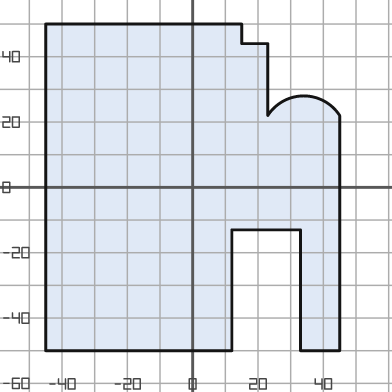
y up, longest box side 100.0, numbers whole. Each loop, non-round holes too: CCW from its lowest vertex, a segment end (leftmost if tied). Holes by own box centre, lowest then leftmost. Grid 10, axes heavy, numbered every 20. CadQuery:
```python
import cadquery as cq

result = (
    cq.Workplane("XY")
    .moveTo(-45.0, -50.0)
    .lineTo(12.0, -50.0)
    .lineTo(12.0, -13.0)
    .lineTo(33.0, -13.0)
    .lineTo(33.0, -50.0)
    .lineTo(45.0, -50.0)
    .lineTo(45.0, 22.0)
    .threePointArc((34.0, 28.0), (23.0, 22.0))
    .lineTo(23.0, 44.0)
    .lineTo(15.0, 44.0)
    .lineTo(15.0, 50.0)
    .lineTo(-45.0, 50.0)
    .close()
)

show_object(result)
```